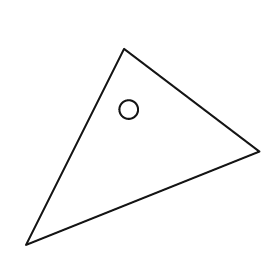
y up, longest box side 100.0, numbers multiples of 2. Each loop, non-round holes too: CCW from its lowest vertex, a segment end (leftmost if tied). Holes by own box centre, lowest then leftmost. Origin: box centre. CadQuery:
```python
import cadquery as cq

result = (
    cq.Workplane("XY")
    .moveTo(-50.0, -42.0)
    .lineTo(50.0, -2.0)
    .lineTo(-8.0, 42.0)
    .close()
    .moveTo(-6.0, 16.0)
    .circle(4.0)
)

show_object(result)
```